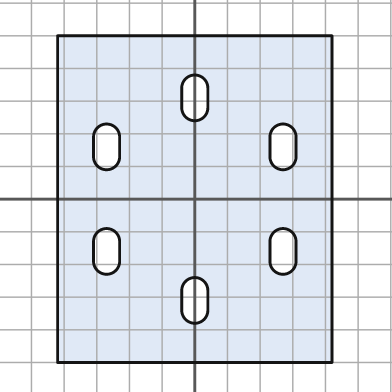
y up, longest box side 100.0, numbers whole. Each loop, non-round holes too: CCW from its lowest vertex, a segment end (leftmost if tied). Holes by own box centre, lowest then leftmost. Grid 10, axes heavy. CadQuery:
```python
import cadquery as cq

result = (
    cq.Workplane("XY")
    .moveTo(-42.0, -50.0)
    .lineTo(42.0, -50.0)
    .lineTo(42.0, 50.0)
    .lineTo(-42.0, 50.0)
    .close()
    .moveTo(-4.0, -34.0)
    .threePointArc((0.0, -38.0), (4.0, -34.0))
    .lineTo(4.0, -28.0)
    .threePointArc((0.0, -24.0), (-4.0, -28.0))
    .close()
    .moveTo(-31.0, -19.0)
    .threePointArc((-27.0, -23.0), (-23.0, -19.0))
    .lineTo(-23.0, -13.0)
    .threePointArc((-27.0, -9.0), (-31.0, -13.0))
    .close()
    .moveTo(23.0, -19.0)
    .threePointArc((27.0, -23.0), (31.0, -19.0))
    .lineTo(31.0, -13.0)
    .threePointArc((27.0, -9.0), (23.0, -13.0))
    .close()
    .moveTo(-31.0, 13.0)
    .threePointArc((-27.0, 9.0), (-23.0, 13.0))
    .lineTo(-23.0, 19.0)
    .threePointArc((-27.0, 23.0), (-31.0, 19.0))
    .close()
    .moveTo(23.0, 13.0)
    .threePointArc((27.0, 9.0), (31.0, 13.0))
    .lineTo(31.0, 19.0)
    .threePointArc((27.0, 23.0), (23.0, 19.0))
    .close()
    .moveTo(-4.0, 28.0)
    .threePointArc((0.0, 24.0), (4.0, 28.0))
    .lineTo(4.0, 34.0)
    .threePointArc((0.0, 38.0), (-4.0, 34.0))
    .close()
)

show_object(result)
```